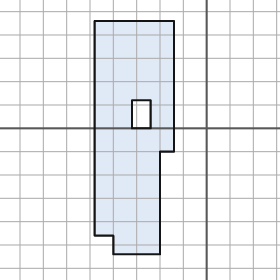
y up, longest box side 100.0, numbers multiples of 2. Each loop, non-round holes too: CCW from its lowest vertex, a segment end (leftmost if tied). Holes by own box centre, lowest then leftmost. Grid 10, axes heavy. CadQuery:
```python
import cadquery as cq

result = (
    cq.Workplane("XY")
    .moveTo(-40.0, -54.0)
    .lineTo(-20.0, -54.0)
    .lineTo(-20.0, -10.0)
    .lineTo(-14.0, -10.0)
    .lineTo(-14.0, 46.0)
    .lineTo(-48.0, 46.0)
    .lineTo(-48.0, -46.0)
    .lineTo(-40.0, -46.0)
    .close()
    .moveTo(-32.0, 0.0)
    .lineTo(-24.0, 0.0)
    .lineTo(-24.0, 12.0)
    .lineTo(-32.0, 12.0)
    .close()
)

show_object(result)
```